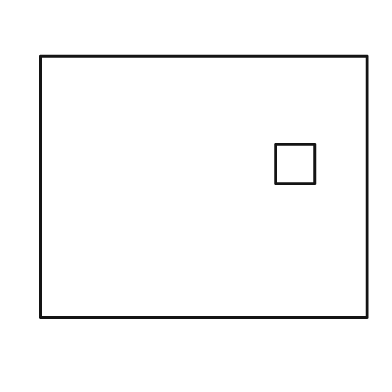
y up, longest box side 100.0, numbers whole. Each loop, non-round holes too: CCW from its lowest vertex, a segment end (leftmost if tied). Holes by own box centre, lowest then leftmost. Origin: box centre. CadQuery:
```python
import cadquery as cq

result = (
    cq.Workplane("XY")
    .moveTo(-50.0, -40.0)
    .lineTo(50.0, -40.0)
    .lineTo(50.0, 40.0)
    .lineTo(-50.0, 40.0)
    .close()
    .moveTo(22.0, 1.0)
    .lineTo(34.0, 1.0)
    .lineTo(34.0, 13.0)
    .lineTo(22.0, 13.0)
    .close()
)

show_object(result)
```